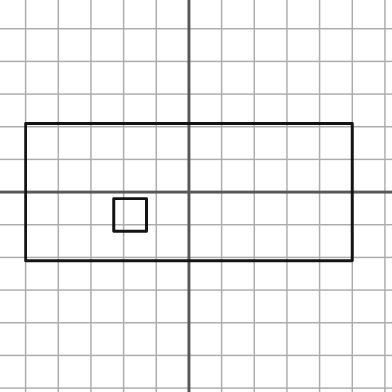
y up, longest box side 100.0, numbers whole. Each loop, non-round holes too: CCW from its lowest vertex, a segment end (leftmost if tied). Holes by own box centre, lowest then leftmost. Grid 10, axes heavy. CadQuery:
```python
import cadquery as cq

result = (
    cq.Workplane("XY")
    .moveTo(-50.0, -21.0)
    .lineTo(50.0, -21.0)
    .lineTo(50.0, 21.0)
    .lineTo(-50.0, 21.0)
    .close()
    .moveTo(-23.0, -12.0)
    .lineTo(-13.0, -12.0)
    .lineTo(-13.0, -2.0)
    .lineTo(-23.0, -2.0)
    .close()
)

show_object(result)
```